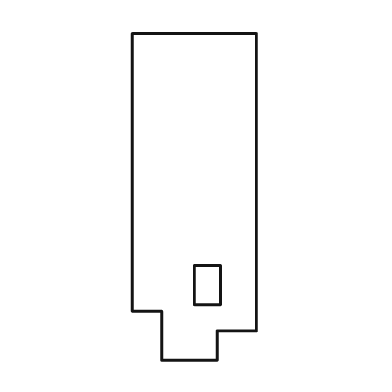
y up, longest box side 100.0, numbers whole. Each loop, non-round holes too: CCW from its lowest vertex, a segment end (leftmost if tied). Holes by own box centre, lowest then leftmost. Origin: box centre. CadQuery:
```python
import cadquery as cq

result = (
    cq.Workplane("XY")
    .moveTo(-10.0, -50.0)
    .lineTo(7.0, -50.0)
    .lineTo(7.0, -41.0)
    .lineTo(19.0, -41.0)
    .lineTo(19.0, 50.0)
    .lineTo(-19.0, 50.0)
    .lineTo(-19.0, -35.0)
    .lineTo(-10.0, -35.0)
    .close()
    .moveTo(0.0, -33.0)
    .lineTo(8.0, -33.0)
    .lineTo(8.0, -21.0)
    .lineTo(0.0, -21.0)
    .close()
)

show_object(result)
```